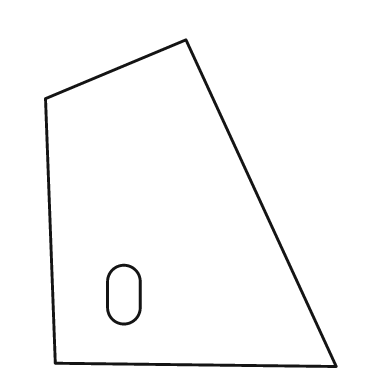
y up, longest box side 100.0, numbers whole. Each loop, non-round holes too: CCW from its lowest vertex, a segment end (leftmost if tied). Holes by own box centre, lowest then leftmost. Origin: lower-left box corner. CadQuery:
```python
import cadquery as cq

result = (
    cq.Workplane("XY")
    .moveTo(89.0, 0.0)
    .lineTo(43.0, 100.0)
    .lineTo(0.0, 82.0)
    .lineTo(3.0, 1.0)
    .close()
    .moveTo(19.0, 18.0)
    .threePointArc((24.0, 13.0), (29.0, 18.0))
    .lineTo(29.0, 26.0)
    .threePointArc((24.0, 31.0), (19.0, 26.0))
    .close()
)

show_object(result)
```